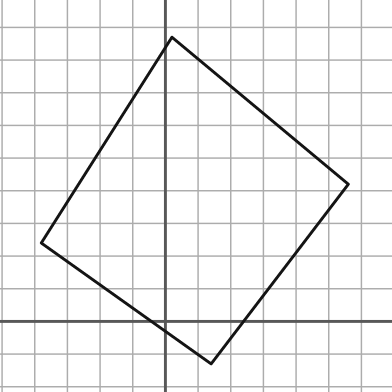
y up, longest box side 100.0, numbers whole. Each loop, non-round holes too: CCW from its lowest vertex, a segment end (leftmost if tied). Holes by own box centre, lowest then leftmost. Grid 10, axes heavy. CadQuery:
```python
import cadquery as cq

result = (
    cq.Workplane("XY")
    .moveTo(14.0, -13.0)
    .lineTo(56.0, 42.0)
    .lineTo(2.0, 87.0)
    .lineTo(-38.0, 24.0)
    .close()
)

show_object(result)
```